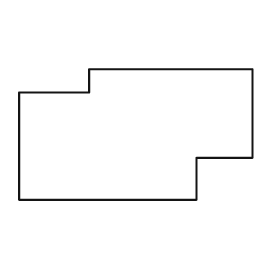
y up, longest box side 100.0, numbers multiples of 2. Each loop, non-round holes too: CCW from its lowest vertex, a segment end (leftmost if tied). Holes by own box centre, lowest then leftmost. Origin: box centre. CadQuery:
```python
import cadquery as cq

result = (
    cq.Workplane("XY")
    .moveTo(-50.0, -28.0)
    .lineTo(26.0, -28.0)
    .lineTo(26.0, -10.0)
    .lineTo(50.0, -10.0)
    .lineTo(50.0, 28.0)
    .lineTo(-20.0, 28.0)
    .lineTo(-20.0, 18.0)
    .lineTo(-50.0, 18.0)
    .close()
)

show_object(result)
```